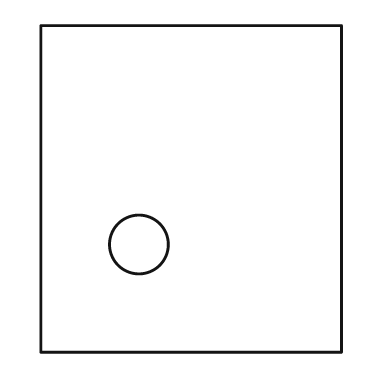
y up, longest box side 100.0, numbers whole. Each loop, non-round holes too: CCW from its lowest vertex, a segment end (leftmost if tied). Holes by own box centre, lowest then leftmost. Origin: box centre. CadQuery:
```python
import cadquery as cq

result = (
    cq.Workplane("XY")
    .moveTo(-46.0, -50.0)
    .lineTo(46.0, -50.0)
    .lineTo(46.0, 50.0)
    .lineTo(-46.0, 50.0)
    .close()
    .moveTo(-16.0, -17.0)
    .circle(9.0)
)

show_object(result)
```